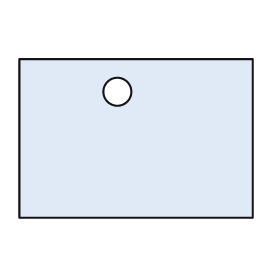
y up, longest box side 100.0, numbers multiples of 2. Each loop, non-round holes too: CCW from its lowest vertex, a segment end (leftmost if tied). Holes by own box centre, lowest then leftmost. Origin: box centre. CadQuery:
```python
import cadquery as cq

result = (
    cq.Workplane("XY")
    .moveTo(-50.0, -34.0)
    .lineTo(50.0, -34.0)
    .lineTo(50.0, 34.0)
    .lineTo(-50.0, 34.0)
    .close()
    .moveTo(-8.0, 20.0)
    .circle(6.0)
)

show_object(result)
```